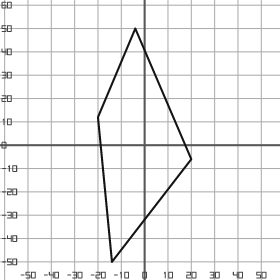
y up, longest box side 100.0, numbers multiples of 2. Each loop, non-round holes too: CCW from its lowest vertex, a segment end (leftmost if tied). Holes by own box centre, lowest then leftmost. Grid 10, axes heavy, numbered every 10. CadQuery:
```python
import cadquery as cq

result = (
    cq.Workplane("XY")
    .moveTo(-14.0, -50.0)
    .lineTo(20.0, -6.0)
    .lineTo(-4.0, 50.0)
    .lineTo(-20.0, 12.0)
    .close()
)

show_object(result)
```